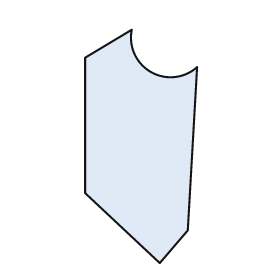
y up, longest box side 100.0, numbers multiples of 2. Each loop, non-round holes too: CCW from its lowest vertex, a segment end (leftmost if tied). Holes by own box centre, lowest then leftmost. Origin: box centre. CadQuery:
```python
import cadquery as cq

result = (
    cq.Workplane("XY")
    .moveTo(8.0, -50.0)
    .lineTo(20.0, -36.0)
    .lineTo(24.0, 34.0)
    .threePointArc((4.0, 32.0), (-4.0, 50.0))
    .lineTo(-24.0, 38.0)
    .lineTo(-24.0, -20.0)
    .close()
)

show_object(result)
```